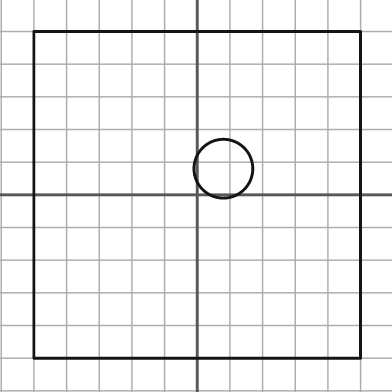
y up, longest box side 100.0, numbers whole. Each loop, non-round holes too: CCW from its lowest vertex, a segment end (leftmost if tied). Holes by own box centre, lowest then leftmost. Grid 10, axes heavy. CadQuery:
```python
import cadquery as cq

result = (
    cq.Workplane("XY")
    .moveTo(-50.0, -50.0)
    .lineTo(50.0, -50.0)
    .lineTo(50.0, 50.0)
    .lineTo(-50.0, 50.0)
    .close()
    .moveTo(8.0, 8.0)
    .circle(9.0)
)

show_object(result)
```